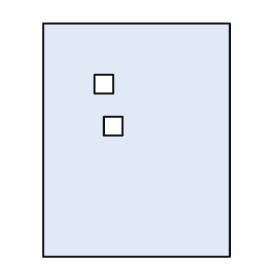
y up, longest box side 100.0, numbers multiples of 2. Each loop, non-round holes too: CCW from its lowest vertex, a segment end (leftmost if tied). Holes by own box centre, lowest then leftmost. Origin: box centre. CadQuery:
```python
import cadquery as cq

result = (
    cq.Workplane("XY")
    .moveTo(-40.0, -50.0)
    .lineTo(40.0, -50.0)
    .lineTo(40.0, 50.0)
    .lineTo(-40.0, 50.0)
    .close()
    .moveTo(-14.0, 2.0)
    .lineTo(-6.0, 2.0)
    .lineTo(-6.0, 10.0)
    .lineTo(-14.0, 10.0)
    .close()
    .moveTo(-18.0, 20.0)
    .lineTo(-10.0, 20.0)
    .lineTo(-10.0, 28.0)
    .lineTo(-18.0, 28.0)
    .close()
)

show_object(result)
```